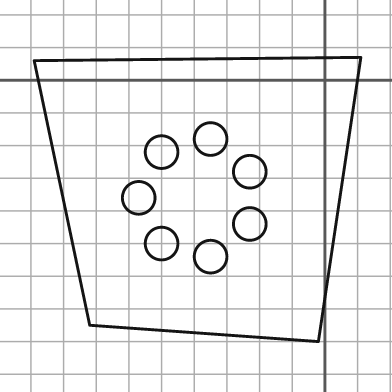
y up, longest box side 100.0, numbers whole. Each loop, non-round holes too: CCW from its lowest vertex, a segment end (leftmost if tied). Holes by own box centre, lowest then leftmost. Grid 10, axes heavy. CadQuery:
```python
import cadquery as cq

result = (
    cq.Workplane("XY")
    .moveTo(-2.0, -80.0)
    .lineTo(11.0, 7.0)
    .lineTo(-89.0, 6.0)
    .lineTo(-72.0, -75.0)
    .close()
    .moveTo(-35.0, -54.0)
    .circle(5.0)
    .moveTo(-50.0, -50.0)
    .circle(5.0)
    .moveTo(-23.0, -44.0)
    .circle(5.0)
    .moveTo(-57.0, -36.0)
    .circle(5.0)
    .moveTo(-23.0, -28.0)
    .circle(5.0)
    .moveTo(-50.0, -22.0)
    .circle(5.0)
    .moveTo(-35.0, -18.0)
    .circle(5.0)
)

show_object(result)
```